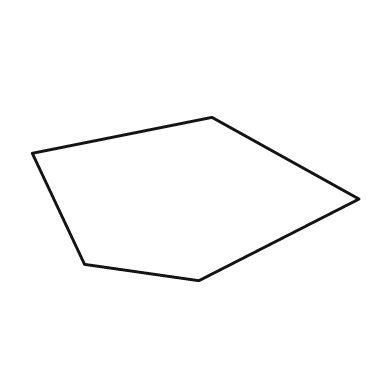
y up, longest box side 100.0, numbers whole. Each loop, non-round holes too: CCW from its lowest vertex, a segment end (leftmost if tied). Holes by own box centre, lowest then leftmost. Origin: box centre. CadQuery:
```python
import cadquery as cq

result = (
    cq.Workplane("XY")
    .moveTo(1.0, -25.0)
    .lineTo(50.0, 0.0)
    .lineTo(5.0, 25.0)
    .lineTo(-50.0, 14.0)
    .lineTo(-34.0, -20.0)
    .close()
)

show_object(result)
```